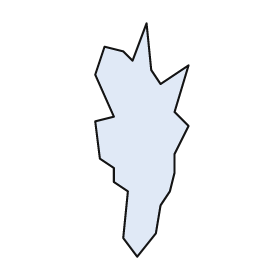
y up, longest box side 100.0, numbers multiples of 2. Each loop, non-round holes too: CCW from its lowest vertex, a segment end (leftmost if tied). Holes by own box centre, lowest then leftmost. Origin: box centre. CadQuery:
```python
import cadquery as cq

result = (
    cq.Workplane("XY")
    .moveTo(-2.0, -50.0)
    .lineTo(6.0, -40.0)
    .lineTo(8.0, -28.0)
    .lineTo(12.0, -22.0)
    .lineTo(14.0, -14.0)
    .lineTo(14.0, -6.0)
    .lineTo(20.0, 6.0)
    .lineTo(14.0, 12.0)
    .lineTo(20.0, 32.0)
    .lineTo(8.0, 24.0)
    .lineTo(4.0, 30.0)
    .lineTo(2.0, 50.0)
    .lineTo(-4.0, 34.0)
    .lineTo(-8.0, 38.0)
    .lineTo(-16.0, 40.0)
    .lineTo(-20.0, 28.0)
    .lineTo(-12.0, 10.0)
    .lineTo(-20.0, 8.0)
    .lineTo(-18.0, -8.0)
    .lineTo(-12.0, -12.0)
    .lineTo(-12.0, -18.0)
    .lineTo(-6.0, -22.0)
    .lineTo(-8.0, -42.0)
    .close()
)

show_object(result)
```